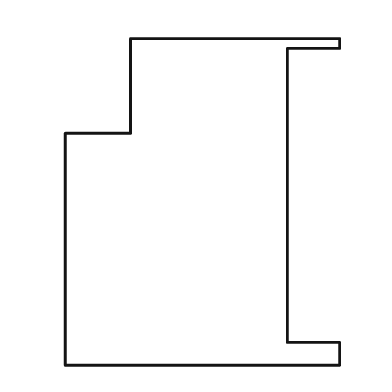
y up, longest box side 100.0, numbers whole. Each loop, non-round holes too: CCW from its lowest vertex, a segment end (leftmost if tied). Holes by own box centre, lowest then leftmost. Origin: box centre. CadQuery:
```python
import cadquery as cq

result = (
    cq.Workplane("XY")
    .moveTo(-42.0, -50.0)
    .lineTo(42.0, -50.0)
    .lineTo(42.0, -43.0)
    .lineTo(26.0, -43.0)
    .lineTo(26.0, 47.0)
    .lineTo(42.0, 47.0)
    .lineTo(42.0, 50.0)
    .lineTo(-22.0, 50.0)
    .lineTo(-22.0, 21.0)
    .lineTo(-42.0, 21.0)
    .close()
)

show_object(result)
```